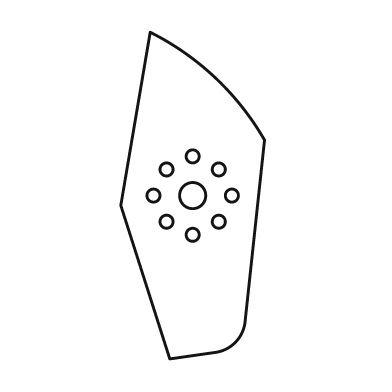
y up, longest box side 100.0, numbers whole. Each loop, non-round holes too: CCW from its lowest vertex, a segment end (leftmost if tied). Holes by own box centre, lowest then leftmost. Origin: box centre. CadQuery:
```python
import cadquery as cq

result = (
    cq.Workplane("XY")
    .moveTo(-7.0, -50.0)
    .lineTo(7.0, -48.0)
    .threePointArc((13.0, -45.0), (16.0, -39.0))
    .lineTo(22.0, 17.0)
    .threePointArc((7.0, 36.0), (-13.0, 50.0))
    .lineTo(-22.0, -3.0)
    .close()
    .moveTo(0.0, -12.0)
    .circle(2.0)
    .moveTo(-8.0, -8.0)
    .circle(2.0)
    .moveTo(8.0, -8.0)
    .circle(2.0)
    .moveTo(-12.0, 0.0)
    .circle(2.0)
    .moveTo(0.0, 0.0)
    .circle(4.0)
    .moveTo(12.0, 0.0)
    .circle(2.0)
    .moveTo(-8.0, 8.0)
    .circle(2.0)
    .moveTo(8.0, 8.0)
    .circle(2.0)
    .moveTo(0.0, 12.0)
    .circle(2.0)
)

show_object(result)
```